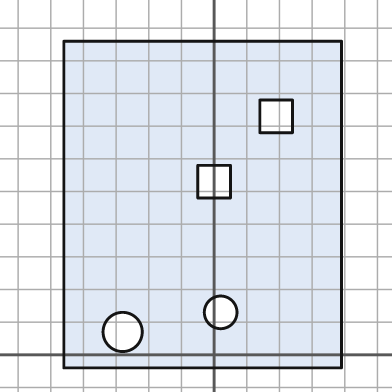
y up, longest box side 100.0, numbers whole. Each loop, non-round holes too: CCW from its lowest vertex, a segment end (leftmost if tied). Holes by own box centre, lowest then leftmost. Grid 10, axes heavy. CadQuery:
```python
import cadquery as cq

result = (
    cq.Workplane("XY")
    .moveTo(-46.0, -4.0)
    .lineTo(39.0, -4.0)
    .lineTo(39.0, 96.0)
    .lineTo(-46.0, 96.0)
    .close()
    .moveTo(-28.0, 7.0)
    .circle(6.0)
    .moveTo(2.0, 13.0)
    .circle(5.0)
    .moveTo(-5.0, 48.0)
    .lineTo(5.0, 48.0)
    .lineTo(5.0, 58.0)
    .lineTo(-5.0, 58.0)
    .close()
    .moveTo(14.0, 68.0)
    .lineTo(24.0, 68.0)
    .lineTo(24.0, 78.0)
    .lineTo(14.0, 78.0)
    .close()
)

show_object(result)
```